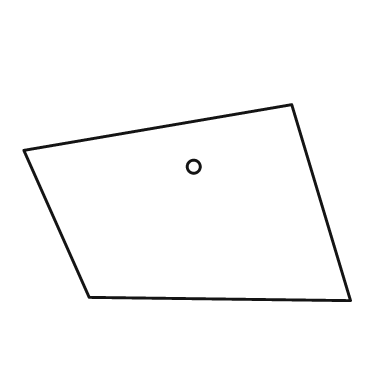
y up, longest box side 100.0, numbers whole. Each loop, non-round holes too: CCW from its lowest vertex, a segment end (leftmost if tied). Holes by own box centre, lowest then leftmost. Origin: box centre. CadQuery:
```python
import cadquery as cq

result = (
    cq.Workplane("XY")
    .moveTo(50.0, -30.0)
    .lineTo(32.0, 30.0)
    .lineTo(-50.0, 16.0)
    .lineTo(-30.0, -29.0)
    .close()
    .moveTo(2.0, 11.0)
    .circle(2.0)
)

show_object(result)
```